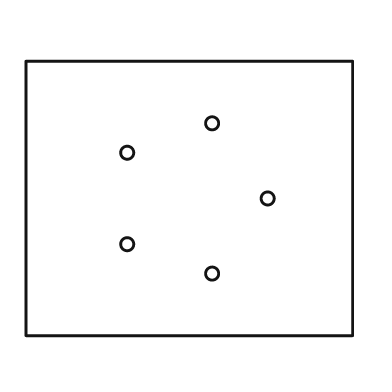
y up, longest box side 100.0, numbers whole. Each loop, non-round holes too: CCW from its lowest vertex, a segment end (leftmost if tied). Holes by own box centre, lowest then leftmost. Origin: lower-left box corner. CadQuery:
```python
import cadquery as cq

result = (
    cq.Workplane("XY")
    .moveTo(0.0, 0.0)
    .lineTo(100.0, 0.0)
    .lineTo(100.0, 84.0)
    .lineTo(0.0, 84.0)
    .close()
    .moveTo(57.0, 19.0)
    .circle(2.0)
    .moveTo(31.0, 28.0)
    .circle(2.0)
    .moveTo(74.0, 42.0)
    .circle(2.0)
    .moveTo(31.0, 56.0)
    .circle(2.0)
    .moveTo(57.0, 65.0)
    .circle(2.0)
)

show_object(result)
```